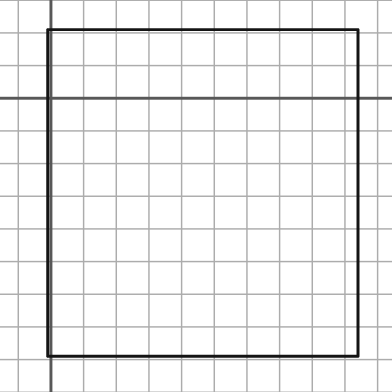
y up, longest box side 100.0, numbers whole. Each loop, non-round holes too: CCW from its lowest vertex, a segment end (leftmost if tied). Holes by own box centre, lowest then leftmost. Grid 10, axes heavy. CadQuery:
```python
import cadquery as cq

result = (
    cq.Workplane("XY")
    .moveTo(-1.0, -79.0)
    .lineTo(94.0, -79.0)
    .lineTo(94.0, 21.0)
    .lineTo(-1.0, 21.0)
    .close()
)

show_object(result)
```